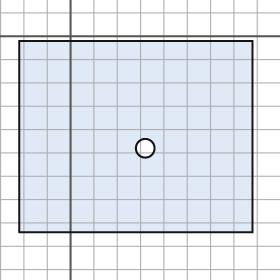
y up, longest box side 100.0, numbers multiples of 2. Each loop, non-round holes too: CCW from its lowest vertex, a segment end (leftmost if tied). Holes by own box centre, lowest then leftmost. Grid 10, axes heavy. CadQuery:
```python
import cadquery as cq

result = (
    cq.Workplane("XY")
    .moveTo(-22.0, -84.0)
    .lineTo(78.0, -84.0)
    .lineTo(78.0, -2.0)
    .lineTo(-22.0, -2.0)
    .close()
    .moveTo(32.0, -48.0)
    .circle(4.0)
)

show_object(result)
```